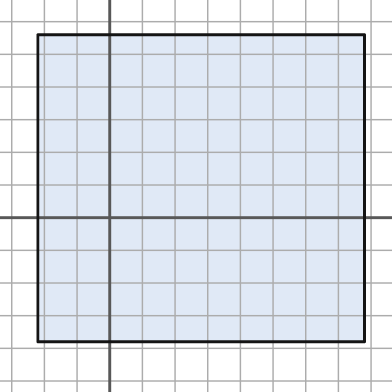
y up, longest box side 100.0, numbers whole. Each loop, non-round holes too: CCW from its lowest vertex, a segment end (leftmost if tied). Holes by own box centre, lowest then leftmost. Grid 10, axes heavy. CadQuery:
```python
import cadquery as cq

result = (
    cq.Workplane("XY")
    .moveTo(-22.0, -38.0)
    .lineTo(78.0, -38.0)
    .lineTo(78.0, 56.0)
    .lineTo(-22.0, 56.0)
    .close()
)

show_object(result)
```